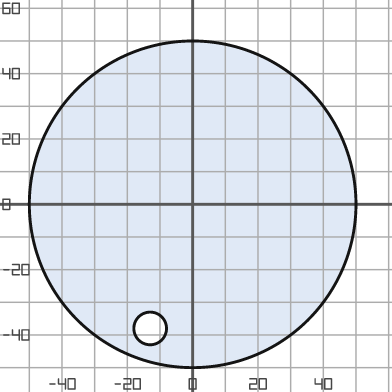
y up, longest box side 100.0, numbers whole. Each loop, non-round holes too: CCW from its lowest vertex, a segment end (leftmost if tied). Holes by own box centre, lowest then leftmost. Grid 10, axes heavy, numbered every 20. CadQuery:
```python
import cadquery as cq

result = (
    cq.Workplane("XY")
    .moveTo(0.0, 0.0)
    .circle(50.0)
    .moveTo(-13.0, -38.0)
    .circle(5.0)
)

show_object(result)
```